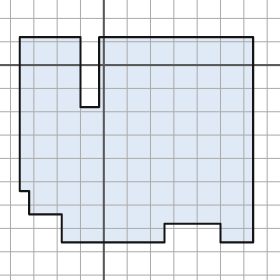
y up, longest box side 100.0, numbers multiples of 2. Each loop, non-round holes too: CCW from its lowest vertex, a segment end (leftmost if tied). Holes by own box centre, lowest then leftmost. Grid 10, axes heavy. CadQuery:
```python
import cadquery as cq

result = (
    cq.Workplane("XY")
    .moveTo(-18.0, -76.0)
    .lineTo(26.0, -76.0)
    .lineTo(26.0, -68.0)
    .lineTo(50.0, -68.0)
    .lineTo(50.0, -76.0)
    .lineTo(64.0, -76.0)
    .lineTo(64.0, 12.0)
    .lineTo(-2.0, 12.0)
    .lineTo(-2.0, -18.0)
    .lineTo(-10.0, -18.0)
    .lineTo(-10.0, 12.0)
    .lineTo(-36.0, 12.0)
    .lineTo(-36.0, -54.0)
    .lineTo(-32.0, -54.0)
    .lineTo(-32.0, -64.0)
    .lineTo(-18.0, -64.0)
    .close()
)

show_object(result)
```